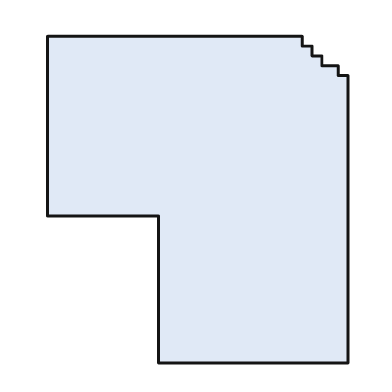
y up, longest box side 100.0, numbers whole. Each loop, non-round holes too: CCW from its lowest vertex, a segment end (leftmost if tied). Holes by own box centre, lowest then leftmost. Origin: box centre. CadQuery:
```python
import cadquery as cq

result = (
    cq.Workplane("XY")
    .moveTo(-12.0, -50.0)
    .lineTo(46.0, -50.0)
    .lineTo(46.0, 38.0)
    .lineTo(43.0, 38.0)
    .lineTo(43.0, 41.0)
    .lineTo(38.0, 41.0)
    .lineTo(38.0, 44.0)
    .lineTo(35.0, 44.0)
    .lineTo(35.0, 47.0)
    .lineTo(32.0, 47.0)
    .lineTo(32.0, 50.0)
    .lineTo(-46.0, 50.0)
    .lineTo(-46.0, -5.0)
    .lineTo(-12.0, -5.0)
    .close()
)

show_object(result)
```